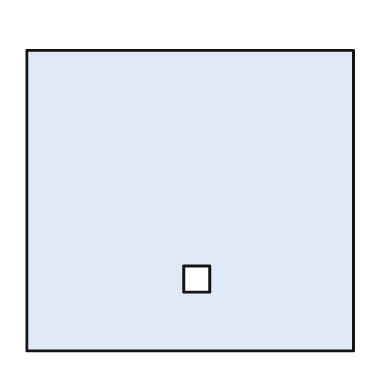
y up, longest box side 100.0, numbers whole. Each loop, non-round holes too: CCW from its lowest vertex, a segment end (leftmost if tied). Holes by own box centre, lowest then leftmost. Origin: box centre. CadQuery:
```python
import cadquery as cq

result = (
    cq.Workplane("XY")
    .moveTo(-50.0, -46.0)
    .lineTo(50.0, -46.0)
    .lineTo(50.0, 46.0)
    .lineTo(-50.0, 46.0)
    .close()
    .moveTo(-2.0, -28.0)
    .lineTo(6.0, -28.0)
    .lineTo(6.0, -20.0)
    .lineTo(-2.0, -20.0)
    .close()
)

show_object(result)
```